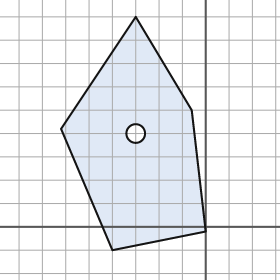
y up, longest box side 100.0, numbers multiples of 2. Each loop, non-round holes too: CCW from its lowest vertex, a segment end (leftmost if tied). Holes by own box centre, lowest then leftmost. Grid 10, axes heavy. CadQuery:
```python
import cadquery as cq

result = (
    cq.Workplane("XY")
    .moveTo(-40.0, -10.0)
    .lineTo(0.0, -2.0)
    .lineTo(-6.0, 50.0)
    .lineTo(-30.0, 90.0)
    .lineTo(-62.0, 42.0)
    .close()
    .moveTo(-30.0, 40.0)
    .circle(4.0)
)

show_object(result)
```